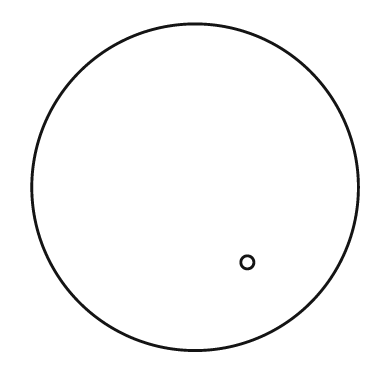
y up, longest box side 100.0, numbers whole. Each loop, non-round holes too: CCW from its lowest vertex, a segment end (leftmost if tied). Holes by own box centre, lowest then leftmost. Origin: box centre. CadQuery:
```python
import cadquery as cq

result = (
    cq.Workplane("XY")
    .moveTo(0.0, 0.0)
    .circle(50.0)
    .moveTo(16.0, -23.0)
    .circle(2.0)
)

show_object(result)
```